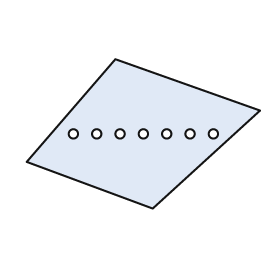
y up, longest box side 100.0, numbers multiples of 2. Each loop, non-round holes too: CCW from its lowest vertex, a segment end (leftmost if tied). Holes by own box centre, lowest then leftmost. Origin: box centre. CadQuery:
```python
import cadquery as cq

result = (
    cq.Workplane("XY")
    .moveTo(4.0, -32.0)
    .lineTo(50.0, 10.0)
    .lineTo(-12.0, 32.0)
    .lineTo(-50.0, -12.0)
    .close()
    .moveTo(-30.0, 0.0)
    .circle(2.0)
    .moveTo(-20.0, 0.0)
    .circle(2.0)
    .moveTo(-10.0, 0.0)
    .circle(2.0)
    .moveTo(0.0, 0.0)
    .circle(2.0)
    .moveTo(10.0, 0.0)
    .circle(2.0)
    .moveTo(20.0, 0.0)
    .circle(2.0)
    .moveTo(30.0, 0.0)
    .circle(2.0)
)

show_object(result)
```